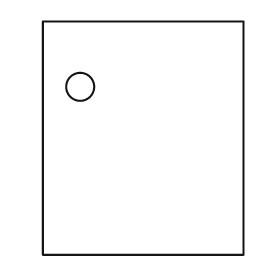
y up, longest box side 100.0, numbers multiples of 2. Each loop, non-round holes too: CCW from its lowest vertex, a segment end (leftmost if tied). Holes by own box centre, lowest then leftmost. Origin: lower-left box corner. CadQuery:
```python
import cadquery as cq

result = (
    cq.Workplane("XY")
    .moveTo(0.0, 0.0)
    .lineTo(86.0, 0.0)
    .lineTo(86.0, 100.0)
    .lineTo(0.0, 100.0)
    .close()
    .moveTo(16.0, 72.0)
    .circle(6.0)
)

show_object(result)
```